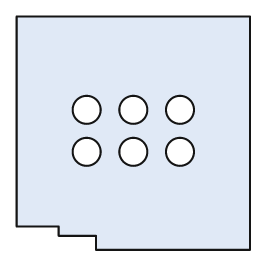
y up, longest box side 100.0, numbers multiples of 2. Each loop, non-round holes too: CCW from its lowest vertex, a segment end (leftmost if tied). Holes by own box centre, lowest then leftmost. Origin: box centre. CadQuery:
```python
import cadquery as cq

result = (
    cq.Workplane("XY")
    .moveTo(-16.0, -50.0)
    .lineTo(50.0, -50.0)
    .lineTo(50.0, 50.0)
    .lineTo(-50.0, 50.0)
    .lineTo(-50.0, -40.0)
    .lineTo(-32.0, -40.0)
    .lineTo(-32.0, -44.0)
    .lineTo(-16.0, -44.0)
    .close()
    .moveTo(-20.0, -8.0)
    .circle(6.0)
    .moveTo(0.0, -8.0)
    .circle(6.0)
    .moveTo(20.0, -8.0)
    .circle(6.0)
    .moveTo(-20.0, 10.0)
    .circle(6.0)
    .moveTo(0.0, 10.0)
    .circle(6.0)
    .moveTo(20.0, 10.0)
    .circle(6.0)
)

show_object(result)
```